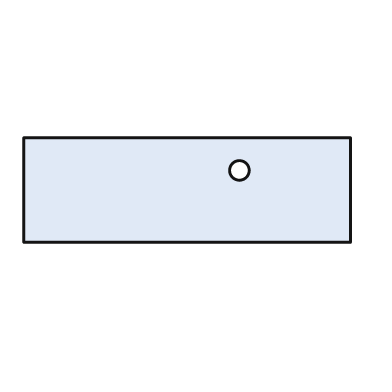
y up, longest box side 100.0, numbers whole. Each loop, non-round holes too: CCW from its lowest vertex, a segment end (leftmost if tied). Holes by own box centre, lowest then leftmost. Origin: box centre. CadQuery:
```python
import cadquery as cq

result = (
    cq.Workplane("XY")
    .moveTo(-50.0, -16.0)
    .lineTo(50.0, -16.0)
    .lineTo(50.0, 16.0)
    .lineTo(-50.0, 16.0)
    .close()
    .moveTo(16.0, 6.0)
    .circle(3.0)
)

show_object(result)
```